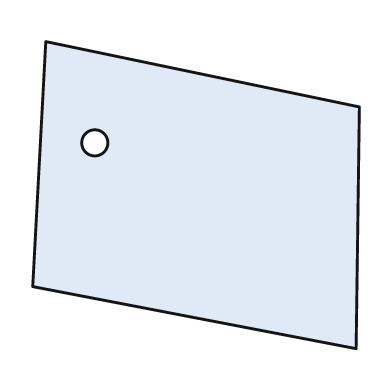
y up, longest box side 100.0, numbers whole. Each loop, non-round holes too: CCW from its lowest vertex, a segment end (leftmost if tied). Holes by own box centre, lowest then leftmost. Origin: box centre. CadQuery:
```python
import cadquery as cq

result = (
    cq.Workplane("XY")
    .moveTo(49.0, -47.0)
    .lineTo(50.0, 27.0)
    .lineTo(-46.0, 47.0)
    .lineTo(-50.0, -28.0)
    .close()
    .moveTo(-31.0, 16.0)
    .circle(4.0)
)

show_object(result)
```